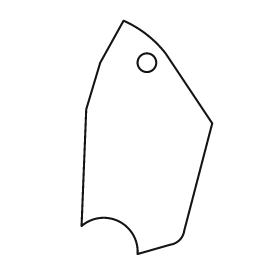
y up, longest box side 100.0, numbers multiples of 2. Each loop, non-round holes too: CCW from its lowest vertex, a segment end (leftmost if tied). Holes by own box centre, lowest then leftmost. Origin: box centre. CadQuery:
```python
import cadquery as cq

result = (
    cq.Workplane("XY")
    .moveTo(-4.0, -50.0)
    .lineTo(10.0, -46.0)
    .threePointArc((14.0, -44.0), (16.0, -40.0))
    .lineTo(28.0, 6.0)
    .lineTo(8.0, 36.0)
    .threePointArc((0.0, 44.0), (-10.0, 50.0))
    .lineTo(-20.0, 32.0)
    .lineTo(-26.0, 12.0)
    .lineTo(-28.0, -38.0)
    .threePointArc((-12.0, -36.0), (-4.0, -50.0))
    .close()
    .moveTo(0.0, 32.0)
    .circle(4.0)
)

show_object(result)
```